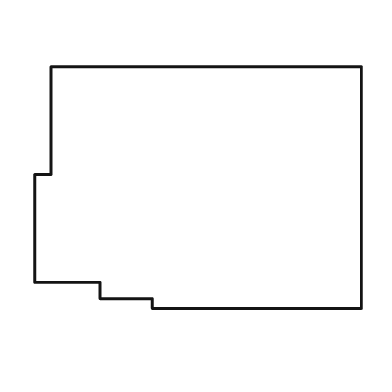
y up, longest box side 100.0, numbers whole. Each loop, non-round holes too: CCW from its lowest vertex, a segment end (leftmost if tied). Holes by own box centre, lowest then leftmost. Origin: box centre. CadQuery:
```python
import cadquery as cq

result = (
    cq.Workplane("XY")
    .moveTo(-14.0, -37.0)
    .lineTo(50.0, -37.0)
    .lineTo(50.0, 37.0)
    .lineTo(-45.0, 37.0)
    .lineTo(-45.0, 4.0)
    .lineTo(-50.0, 4.0)
    .lineTo(-50.0, -29.0)
    .lineTo(-30.0, -29.0)
    .lineTo(-30.0, -34.0)
    .lineTo(-14.0, -34.0)
    .close()
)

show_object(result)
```